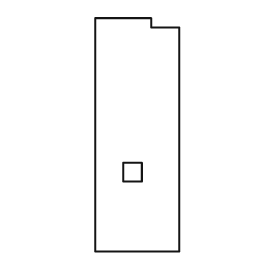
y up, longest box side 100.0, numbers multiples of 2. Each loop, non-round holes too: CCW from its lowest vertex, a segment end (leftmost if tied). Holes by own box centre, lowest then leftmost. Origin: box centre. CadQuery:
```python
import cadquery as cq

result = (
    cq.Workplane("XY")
    .moveTo(-18.0, -50.0)
    .lineTo(18.0, -50.0)
    .lineTo(18.0, 46.0)
    .lineTo(6.0, 46.0)
    .lineTo(6.0, 50.0)
    .lineTo(-18.0, 50.0)
    .close()
    .moveTo(-6.0, -20.0)
    .lineTo(2.0, -20.0)
    .lineTo(2.0, -12.0)
    .lineTo(-6.0, -12.0)
    .close()
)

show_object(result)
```